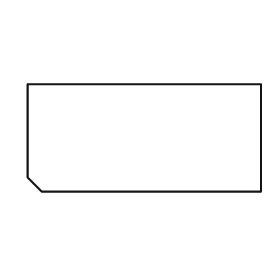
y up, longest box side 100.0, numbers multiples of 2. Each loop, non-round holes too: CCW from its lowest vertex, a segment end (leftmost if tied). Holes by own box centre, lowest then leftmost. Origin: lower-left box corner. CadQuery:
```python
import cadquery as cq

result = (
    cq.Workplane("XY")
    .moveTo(6.0, 0.0)
    .lineTo(100.0, 0.0)
    .lineTo(100.0, 46.0)
    .lineTo(0.0, 46.0)
    .lineTo(0.0, 6.0)
    .close()
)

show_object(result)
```